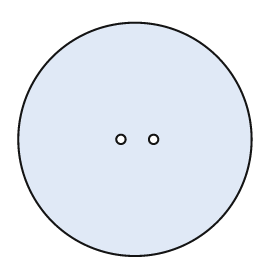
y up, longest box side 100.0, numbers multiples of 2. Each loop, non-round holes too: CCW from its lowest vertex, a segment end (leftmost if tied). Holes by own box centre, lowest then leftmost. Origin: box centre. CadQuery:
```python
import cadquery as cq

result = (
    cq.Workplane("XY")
    .moveTo(0.0, 0.0)
    .circle(50.0)
    .moveTo(-6.0, 0.0)
    .circle(2.0)
    .moveTo(8.0, 0.0)
    .circle(2.0)
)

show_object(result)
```